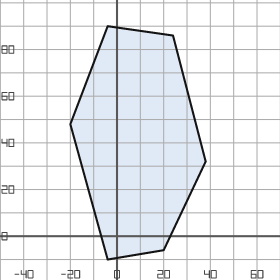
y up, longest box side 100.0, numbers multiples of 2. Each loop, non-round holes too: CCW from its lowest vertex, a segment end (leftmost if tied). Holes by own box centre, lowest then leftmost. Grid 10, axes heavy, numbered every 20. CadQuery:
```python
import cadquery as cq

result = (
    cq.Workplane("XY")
    .moveTo(-4.0, -10.0)
    .lineTo(20.0, -6.0)
    .lineTo(38.0, 32.0)
    .lineTo(24.0, 86.0)
    .lineTo(-4.0, 90.0)
    .lineTo(-20.0, 48.0)
    .close()
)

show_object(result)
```